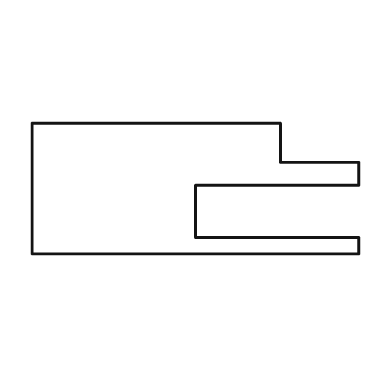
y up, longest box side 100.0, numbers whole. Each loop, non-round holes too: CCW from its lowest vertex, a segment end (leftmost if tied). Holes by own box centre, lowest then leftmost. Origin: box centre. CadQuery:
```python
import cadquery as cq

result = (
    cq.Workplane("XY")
    .moveTo(-50.0, -20.0)
    .lineTo(50.0, -20.0)
    .lineTo(50.0, -15.0)
    .lineTo(0.0, -15.0)
    .lineTo(0.0, 1.0)
    .lineTo(50.0, 1.0)
    .lineTo(50.0, 8.0)
    .lineTo(26.0, 8.0)
    .lineTo(26.0, 20.0)
    .lineTo(-50.0, 20.0)
    .close()
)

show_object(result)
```